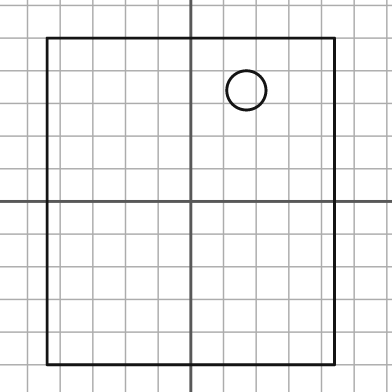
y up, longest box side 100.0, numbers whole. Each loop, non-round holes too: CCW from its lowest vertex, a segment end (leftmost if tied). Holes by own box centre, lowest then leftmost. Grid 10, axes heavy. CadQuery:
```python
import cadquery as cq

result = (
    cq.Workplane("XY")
    .moveTo(-44.0, -50.0)
    .lineTo(44.0, -50.0)
    .lineTo(44.0, 50.0)
    .lineTo(-44.0, 50.0)
    .close()
    .moveTo(17.0, 34.0)
    .circle(6.0)
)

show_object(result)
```